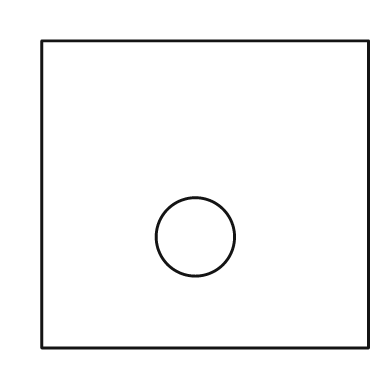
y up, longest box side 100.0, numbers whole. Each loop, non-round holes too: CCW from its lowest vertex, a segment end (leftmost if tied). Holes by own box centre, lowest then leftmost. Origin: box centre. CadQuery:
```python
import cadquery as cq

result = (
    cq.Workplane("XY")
    .moveTo(-50.0, -47.0)
    .lineTo(50.0, -47.0)
    .lineTo(50.0, 47.0)
    .lineTo(-50.0, 47.0)
    .close()
    .moveTo(-3.0, -13.0)
    .circle(12.0)
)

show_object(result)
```